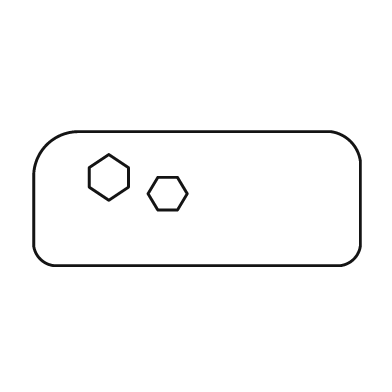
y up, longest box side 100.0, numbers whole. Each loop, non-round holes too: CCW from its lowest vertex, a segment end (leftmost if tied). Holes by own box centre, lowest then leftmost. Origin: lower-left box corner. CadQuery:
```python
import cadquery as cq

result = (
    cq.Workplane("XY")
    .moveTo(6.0, 0.0)
    .lineTo(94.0, 0.0)
    .threePointArc((98.0, 2.0), (100.0, 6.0))
    .lineTo(100.0, 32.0)
    .threePointArc((97.0, 38.0), (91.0, 41.0))
    .lineTo(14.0, 41.0)
    .threePointArc((4.0, 37.0), (0.0, 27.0))
    .lineTo(0.0, 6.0)
    .threePointArc((2.0, 2.0), (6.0, 0.0))
    .close()
    .moveTo(38.0, 17.0)
    .lineTo(44.0, 17.0)
    .lineTo(47.0, 22.0)
    .lineTo(44.0, 27.0)
    .lineTo(38.0, 27.0)
    .lineTo(35.0, 22.0)
    .close()
    .moveTo(23.0, 20.0)
    .lineTo(29.0, 24.0)
    .lineTo(29.0, 30.0)
    .lineTo(23.0, 34.0)
    .lineTo(17.0, 30.0)
    .lineTo(17.0, 24.0)
    .close()
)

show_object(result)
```